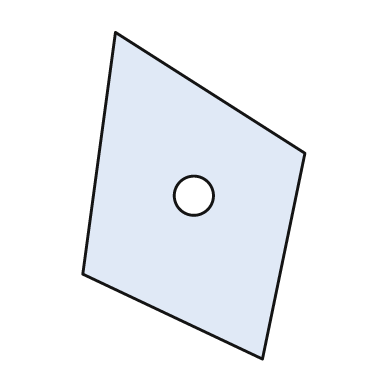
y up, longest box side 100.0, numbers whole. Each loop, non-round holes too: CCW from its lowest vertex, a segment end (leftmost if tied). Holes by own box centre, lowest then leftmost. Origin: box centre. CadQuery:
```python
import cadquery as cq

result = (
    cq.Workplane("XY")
    .moveTo(21.0, -50.0)
    .lineTo(34.0, 13.0)
    .lineTo(-24.0, 50.0)
    .lineTo(-34.0, -24.0)
    .close()
    .moveTo(0.0, 0.0)
    .circle(6.0)
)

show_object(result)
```